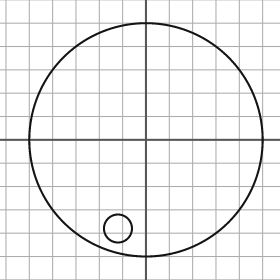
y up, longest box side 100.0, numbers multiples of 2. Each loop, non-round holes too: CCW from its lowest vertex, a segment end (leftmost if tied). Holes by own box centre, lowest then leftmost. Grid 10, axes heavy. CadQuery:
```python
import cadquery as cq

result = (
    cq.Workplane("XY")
    .moveTo(0.0, 0.0)
    .circle(50.0)
    .moveTo(-12.0, -38.0)
    .circle(6.0)
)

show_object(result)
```